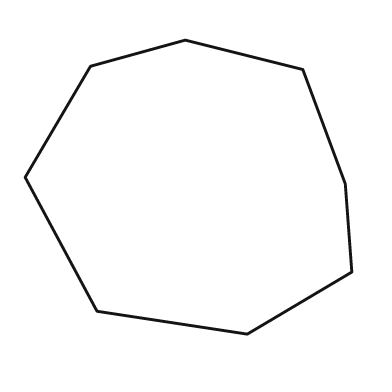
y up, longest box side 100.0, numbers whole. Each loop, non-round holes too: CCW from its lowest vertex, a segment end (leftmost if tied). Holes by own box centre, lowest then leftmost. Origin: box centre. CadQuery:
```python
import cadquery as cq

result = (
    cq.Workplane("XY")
    .moveTo(18.0, -45.0)
    .lineTo(50.0, -26.0)
    .lineTo(48.0, 1.0)
    .lineTo(35.0, 36.0)
    .lineTo(-1.0, 45.0)
    .lineTo(-30.0, 37.0)
    .lineTo(-50.0, 3.0)
    .lineTo(-28.0, -38.0)
    .close()
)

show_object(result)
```